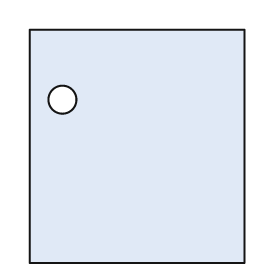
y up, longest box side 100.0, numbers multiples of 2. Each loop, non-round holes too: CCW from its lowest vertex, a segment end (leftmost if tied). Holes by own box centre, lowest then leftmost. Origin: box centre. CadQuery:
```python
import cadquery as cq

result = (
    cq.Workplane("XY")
    .moveTo(-46.0, -50.0)
    .lineTo(46.0, -50.0)
    .lineTo(46.0, 50.0)
    .lineTo(-46.0, 50.0)
    .close()
    .moveTo(-32.0, 20.0)
    .circle(6.0)
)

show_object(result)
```